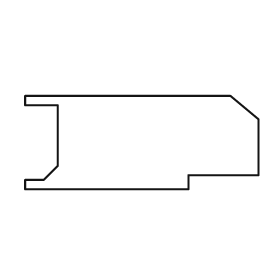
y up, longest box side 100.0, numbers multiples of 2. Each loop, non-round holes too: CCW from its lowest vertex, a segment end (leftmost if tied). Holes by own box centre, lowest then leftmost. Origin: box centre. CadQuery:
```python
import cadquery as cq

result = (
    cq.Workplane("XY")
    .moveTo(-50.0, -20.0)
    .lineTo(20.0, -20.0)
    .lineTo(20.0, -14.0)
    .lineTo(50.0, -14.0)
    .lineTo(50.0, 10.0)
    .lineTo(38.0, 20.0)
    .lineTo(-50.0, 20.0)
    .lineTo(-50.0, 16.0)
    .lineTo(-36.0, 16.0)
    .lineTo(-36.0, -10.0)
    .lineTo(-42.0, -16.0)
    .lineTo(-50.0, -16.0)
    .close()
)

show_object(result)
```